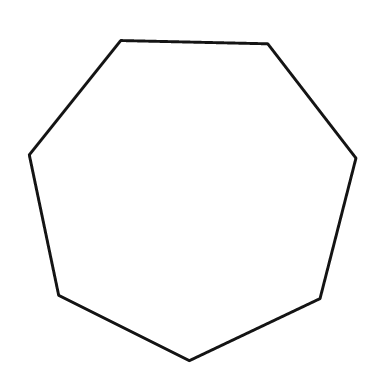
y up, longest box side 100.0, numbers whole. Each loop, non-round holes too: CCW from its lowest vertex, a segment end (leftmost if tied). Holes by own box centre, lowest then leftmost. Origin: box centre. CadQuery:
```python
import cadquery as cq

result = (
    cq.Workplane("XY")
    .moveTo(-1.0, -49.0)
    .lineTo(39.0, -30.0)
    .lineTo(50.0, 13.0)
    .lineTo(23.0, 48.0)
    .lineTo(-22.0, 49.0)
    .lineTo(-50.0, 14.0)
    .lineTo(-41.0, -29.0)
    .close()
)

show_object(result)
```